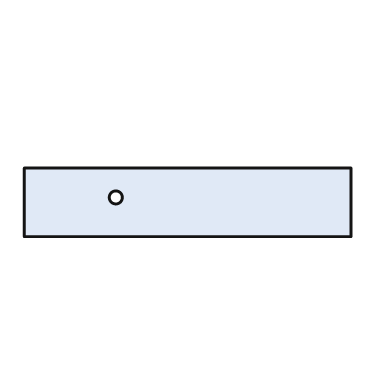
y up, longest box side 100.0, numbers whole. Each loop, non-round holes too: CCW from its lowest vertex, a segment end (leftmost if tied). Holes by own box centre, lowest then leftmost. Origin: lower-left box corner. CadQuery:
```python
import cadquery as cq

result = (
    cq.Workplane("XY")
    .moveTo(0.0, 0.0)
    .lineTo(100.0, 0.0)
    .lineTo(100.0, 21.0)
    .lineTo(0.0, 21.0)
    .close()
    .moveTo(28.0, 12.0)
    .circle(2.0)
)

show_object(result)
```